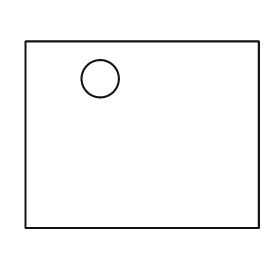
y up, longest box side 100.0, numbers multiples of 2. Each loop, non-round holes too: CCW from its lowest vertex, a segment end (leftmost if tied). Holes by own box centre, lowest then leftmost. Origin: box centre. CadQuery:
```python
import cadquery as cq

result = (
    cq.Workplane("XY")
    .moveTo(-50.0, -40.0)
    .lineTo(50.0, -40.0)
    .lineTo(50.0, 40.0)
    .lineTo(-50.0, 40.0)
    .close()
    .moveTo(-18.0, 24.0)
    .circle(8.0)
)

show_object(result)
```